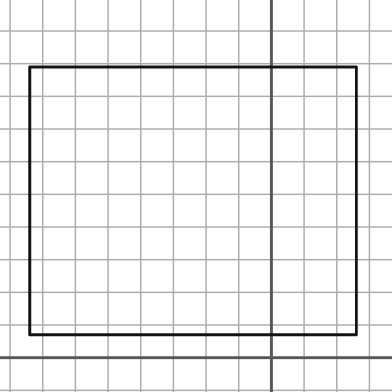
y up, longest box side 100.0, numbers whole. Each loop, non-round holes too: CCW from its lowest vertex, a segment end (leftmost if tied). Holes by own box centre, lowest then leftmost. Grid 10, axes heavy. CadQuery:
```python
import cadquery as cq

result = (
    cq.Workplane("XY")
    .moveTo(-74.0, 7.0)
    .lineTo(26.0, 7.0)
    .lineTo(26.0, 89.0)
    .lineTo(-74.0, 89.0)
    .close()
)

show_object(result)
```